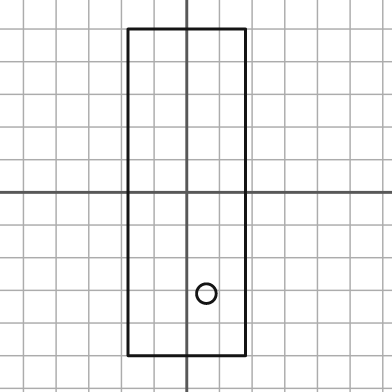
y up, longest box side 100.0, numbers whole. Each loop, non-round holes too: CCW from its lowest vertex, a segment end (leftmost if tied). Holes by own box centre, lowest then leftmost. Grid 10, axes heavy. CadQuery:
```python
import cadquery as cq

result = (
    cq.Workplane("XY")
    .moveTo(-18.0, -50.0)
    .lineTo(18.0, -50.0)
    .lineTo(18.0, 50.0)
    .lineTo(-18.0, 50.0)
    .close()
    .moveTo(6.0, -31.0)
    .circle(3.0)
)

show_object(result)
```